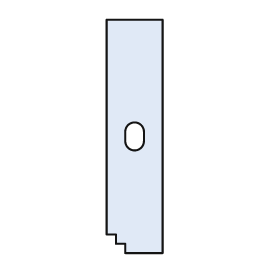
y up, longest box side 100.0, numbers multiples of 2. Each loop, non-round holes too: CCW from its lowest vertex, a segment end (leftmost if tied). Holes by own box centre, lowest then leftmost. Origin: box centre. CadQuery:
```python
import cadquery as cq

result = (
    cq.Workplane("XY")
    .moveTo(-4.0, -50.0)
    .lineTo(12.0, -50.0)
    .lineTo(12.0, 50.0)
    .lineTo(-12.0, 50.0)
    .lineTo(-12.0, -42.0)
    .lineTo(-8.0, -42.0)
    .lineTo(-8.0, -46.0)
    .lineTo(-4.0, -46.0)
    .close()
    .moveTo(-4.0, -2.0)
    .threePointArc((0.0, -6.0), (4.0, -2.0))
    .lineTo(4.0, 2.0)
    .threePointArc((0.0, 6.0), (-4.0, 2.0))
    .close()
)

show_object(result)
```